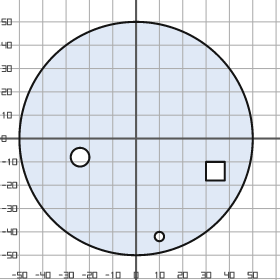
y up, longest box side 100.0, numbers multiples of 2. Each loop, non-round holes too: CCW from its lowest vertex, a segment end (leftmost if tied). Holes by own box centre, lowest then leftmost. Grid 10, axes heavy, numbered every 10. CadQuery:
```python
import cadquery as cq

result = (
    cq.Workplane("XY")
    .moveTo(0.0, 0.0)
    .circle(50.0)
    .moveTo(10.0, -42.0)
    .circle(2.0)
    .moveTo(30.0, -18.0)
    .lineTo(38.0, -18.0)
    .lineTo(38.0, -10.0)
    .lineTo(30.0, -10.0)
    .close()
    .moveTo(-24.0, -8.0)
    .circle(4.0)
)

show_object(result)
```